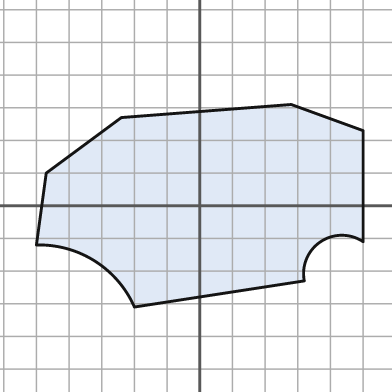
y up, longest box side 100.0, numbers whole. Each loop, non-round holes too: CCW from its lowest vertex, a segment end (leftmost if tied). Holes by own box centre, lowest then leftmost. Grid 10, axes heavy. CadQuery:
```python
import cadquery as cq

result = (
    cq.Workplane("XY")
    .moveTo(-20.0, -31.0)
    .lineTo(32.0, -23.0)
    .threePointArc((37.0, -11.0), (50.0, -11.0))
    .lineTo(50.0, 23.0)
    .lineTo(28.0, 31.0)
    .lineTo(-24.0, 27.0)
    .lineTo(-47.0, 10.0)
    .lineTo(-50.0, -12.0)
    .threePointArc((-32.0, -17.0), (-20.0, -31.0))
    .close()
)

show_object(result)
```